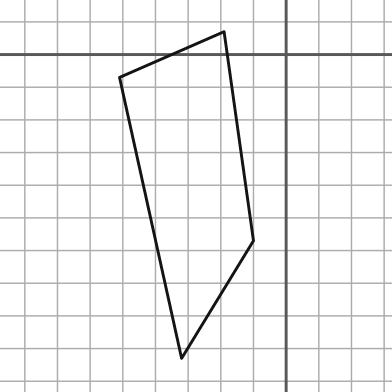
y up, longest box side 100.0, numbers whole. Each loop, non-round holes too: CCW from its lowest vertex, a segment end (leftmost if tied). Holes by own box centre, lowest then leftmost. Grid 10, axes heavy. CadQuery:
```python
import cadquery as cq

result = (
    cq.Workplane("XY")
    .moveTo(-32.0, -93.0)
    .lineTo(-10.0, -57.0)
    .lineTo(-19.0, 7.0)
    .lineTo(-51.0, -7.0)
    .close()
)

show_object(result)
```